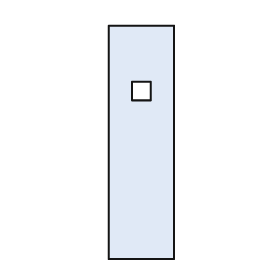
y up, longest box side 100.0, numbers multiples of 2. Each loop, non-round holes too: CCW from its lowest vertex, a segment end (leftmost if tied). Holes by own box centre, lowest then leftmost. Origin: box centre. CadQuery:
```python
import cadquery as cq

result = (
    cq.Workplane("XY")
    .moveTo(-14.0, -50.0)
    .lineTo(14.0, -50.0)
    .lineTo(14.0, 50.0)
    .lineTo(-14.0, 50.0)
    .close()
    .moveTo(-4.0, 18.0)
    .lineTo(4.0, 18.0)
    .lineTo(4.0, 26.0)
    .lineTo(-4.0, 26.0)
    .close()
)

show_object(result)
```